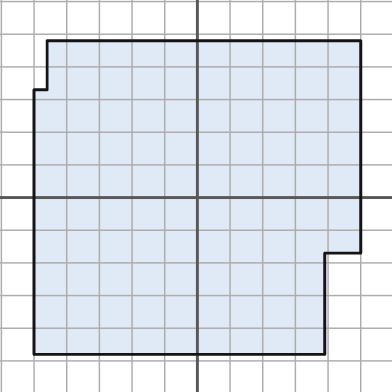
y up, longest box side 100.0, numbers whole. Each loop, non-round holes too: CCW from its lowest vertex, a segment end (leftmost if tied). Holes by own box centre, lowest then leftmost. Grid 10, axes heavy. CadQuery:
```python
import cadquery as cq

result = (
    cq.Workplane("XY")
    .moveTo(-50.0, -48.0)
    .lineTo(39.0, -48.0)
    .lineTo(39.0, -17.0)
    .lineTo(50.0, -17.0)
    .lineTo(50.0, 48.0)
    .lineTo(-46.0, 48.0)
    .lineTo(-46.0, 33.0)
    .lineTo(-50.0, 33.0)
    .close()
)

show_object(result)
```